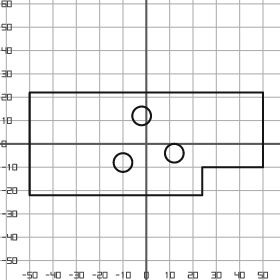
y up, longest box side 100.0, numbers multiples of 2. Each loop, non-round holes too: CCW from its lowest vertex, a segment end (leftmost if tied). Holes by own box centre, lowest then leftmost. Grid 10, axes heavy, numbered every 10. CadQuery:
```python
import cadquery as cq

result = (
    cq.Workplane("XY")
    .moveTo(-50.0, -22.0)
    .lineTo(24.0, -22.0)
    .lineTo(24.0, -10.0)
    .lineTo(50.0, -10.0)
    .lineTo(50.0, 22.0)
    .lineTo(-50.0, 22.0)
    .close()
    .moveTo(-10.0, -8.0)
    .circle(4.0)
    .moveTo(12.0, -4.0)
    .circle(4.0)
    .moveTo(-2.0, 12.0)
    .circle(4.0)
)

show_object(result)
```